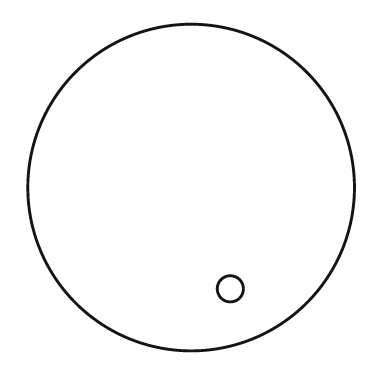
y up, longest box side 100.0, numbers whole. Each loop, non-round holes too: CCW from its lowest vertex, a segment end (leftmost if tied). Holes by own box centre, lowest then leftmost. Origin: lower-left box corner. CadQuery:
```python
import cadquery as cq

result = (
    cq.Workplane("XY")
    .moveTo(50.0, 50.0)
    .circle(50.0)
    .moveTo(62.0, 19.0)
    .circle(4.0)
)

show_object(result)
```